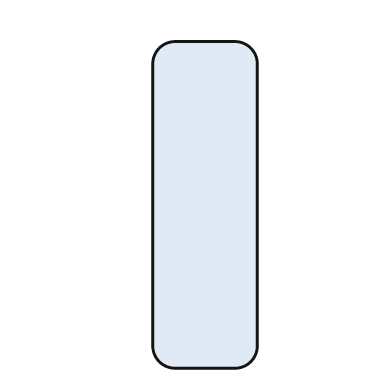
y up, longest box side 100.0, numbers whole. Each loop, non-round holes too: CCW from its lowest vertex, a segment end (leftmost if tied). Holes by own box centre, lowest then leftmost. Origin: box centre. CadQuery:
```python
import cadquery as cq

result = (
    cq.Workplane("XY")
    .moveTo(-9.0, -50.0)
    .lineTo(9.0, -50.0)
    .threePointArc((14.0, -48.0), (16.0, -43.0))
    .lineTo(16.0, 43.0)
    .threePointArc((14.0, 48.0), (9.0, 50.0))
    .lineTo(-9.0, 50.0)
    .threePointArc((-14.0, 48.0), (-16.0, 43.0))
    .lineTo(-16.0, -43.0)
    .threePointArc((-14.0, -48.0), (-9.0, -50.0))
    .close()
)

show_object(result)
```